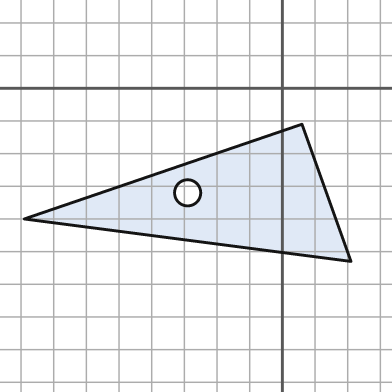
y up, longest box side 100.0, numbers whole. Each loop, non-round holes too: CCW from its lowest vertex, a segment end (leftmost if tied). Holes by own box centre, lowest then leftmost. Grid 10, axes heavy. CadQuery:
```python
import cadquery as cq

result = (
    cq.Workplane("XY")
    .moveTo(21.0, -53.0)
    .lineTo(6.0, -11.0)
    .lineTo(-79.0, -40.0)
    .close()
    .moveTo(-29.0, -32.0)
    .circle(4.0)
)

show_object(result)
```